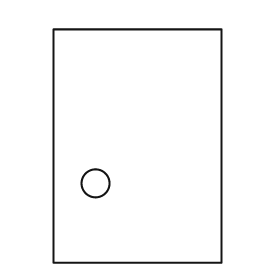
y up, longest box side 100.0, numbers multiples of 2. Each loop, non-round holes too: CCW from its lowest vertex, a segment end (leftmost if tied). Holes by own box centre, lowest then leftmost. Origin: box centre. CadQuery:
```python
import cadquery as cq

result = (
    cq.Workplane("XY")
    .moveTo(-36.0, -50.0)
    .lineTo(36.0, -50.0)
    .lineTo(36.0, 50.0)
    .lineTo(-36.0, 50.0)
    .close()
    .moveTo(-18.0, -16.0)
    .circle(6.0)
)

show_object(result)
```